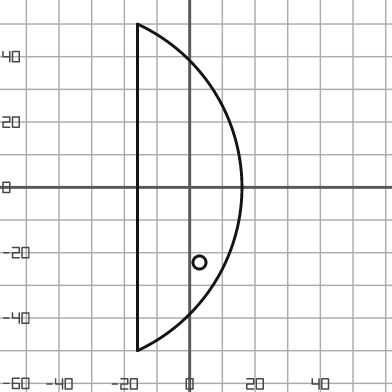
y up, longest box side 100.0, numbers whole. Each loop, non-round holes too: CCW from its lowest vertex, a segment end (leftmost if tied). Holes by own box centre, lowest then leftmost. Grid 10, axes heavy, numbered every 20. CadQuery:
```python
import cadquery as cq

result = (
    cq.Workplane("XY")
    .moveTo(-16.0, -50.0)
    .threePointArc((16.0, 0.0), (-16.0, 50.0))
    .close()
    .moveTo(3.0, -23.0)
    .circle(2.0)
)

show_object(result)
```